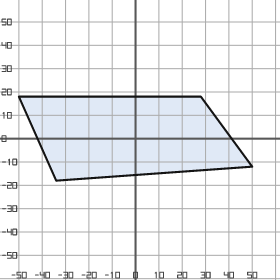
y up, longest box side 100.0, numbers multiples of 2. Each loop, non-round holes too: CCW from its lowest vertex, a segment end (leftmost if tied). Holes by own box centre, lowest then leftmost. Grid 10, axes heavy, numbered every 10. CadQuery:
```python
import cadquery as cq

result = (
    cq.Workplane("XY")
    .moveTo(-34.0, -18.0)
    .lineTo(50.0, -12.0)
    .lineTo(28.0, 18.0)
    .lineTo(-50.0, 18.0)
    .close()
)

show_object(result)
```